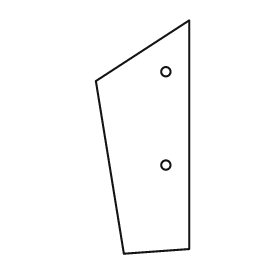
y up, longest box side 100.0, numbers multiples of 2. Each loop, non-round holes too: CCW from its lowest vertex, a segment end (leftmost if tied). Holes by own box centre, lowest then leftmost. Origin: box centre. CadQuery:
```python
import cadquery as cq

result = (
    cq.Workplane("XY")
    .moveTo(-8.0, -50.0)
    .lineTo(20.0, -48.0)
    .lineTo(20.0, 50.0)
    .lineTo(-20.0, 24.0)
    .close()
    .moveTo(10.0, -12.0)
    .circle(2.0)
    .moveTo(10.0, 28.0)
    .circle(2.0)
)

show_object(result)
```